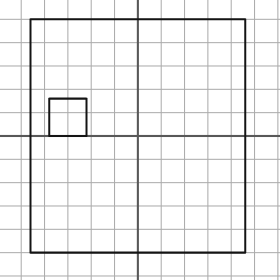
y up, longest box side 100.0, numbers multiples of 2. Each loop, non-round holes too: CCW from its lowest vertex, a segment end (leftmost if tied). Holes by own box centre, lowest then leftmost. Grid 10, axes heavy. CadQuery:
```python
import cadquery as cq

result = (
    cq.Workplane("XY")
    .moveTo(-46.0, -50.0)
    .lineTo(46.0, -50.0)
    .lineTo(46.0, 50.0)
    .lineTo(-46.0, 50.0)
    .close()
    .moveTo(-38.0, 0.0)
    .lineTo(-22.0, 0.0)
    .lineTo(-22.0, 16.0)
    .lineTo(-38.0, 16.0)
    .close()
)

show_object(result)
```